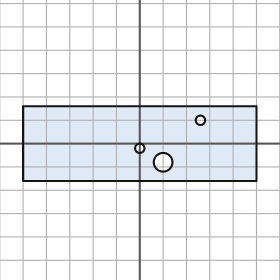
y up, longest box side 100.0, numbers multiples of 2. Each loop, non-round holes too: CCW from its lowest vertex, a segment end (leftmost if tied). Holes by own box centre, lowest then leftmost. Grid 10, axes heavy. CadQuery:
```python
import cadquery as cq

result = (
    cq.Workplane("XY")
    .moveTo(-50.0, -16.0)
    .lineTo(50.0, -16.0)
    .lineTo(50.0, 16.0)
    .lineTo(-50.0, 16.0)
    .close()
    .moveTo(10.0, -8.0)
    .circle(4.0)
    .moveTo(0.0, -2.0)
    .circle(2.0)
    .moveTo(26.0, 10.0)
    .circle(2.0)
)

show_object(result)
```